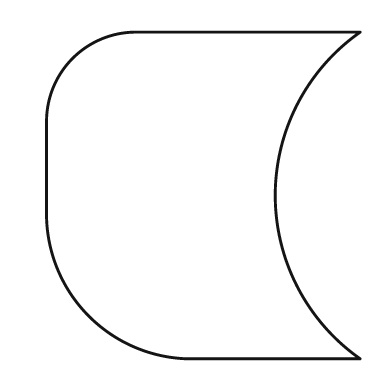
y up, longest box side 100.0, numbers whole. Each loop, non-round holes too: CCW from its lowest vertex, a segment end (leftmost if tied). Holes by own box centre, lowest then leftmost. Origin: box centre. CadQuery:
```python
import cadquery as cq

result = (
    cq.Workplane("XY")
    .moveTo(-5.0, -50.0)
    .lineTo(48.0, -50.0)
    .threePointArc((22.0, 0.0), (48.0, 50.0))
    .lineTo(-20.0, 50.0)
    .threePointArc((-40.0, 42.0), (-48.0, 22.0))
    .lineTo(-48.0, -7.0)
    .threePointArc((-35.0, -37.0), (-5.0, -50.0))
    .close()
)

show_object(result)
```